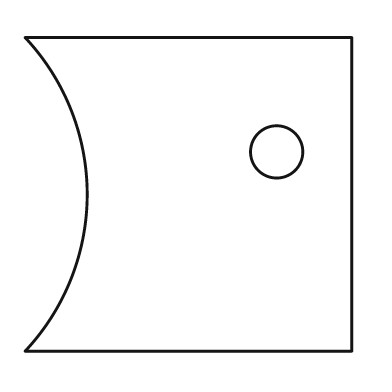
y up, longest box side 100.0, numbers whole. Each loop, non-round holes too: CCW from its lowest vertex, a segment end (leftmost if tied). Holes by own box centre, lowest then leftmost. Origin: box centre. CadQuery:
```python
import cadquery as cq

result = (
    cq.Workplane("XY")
    .moveTo(-50.0, -48.0)
    .lineTo(50.0, -48.0)
    .lineTo(50.0, 48.0)
    .lineTo(-50.0, 48.0)
    .threePointArc((-31.0, 0.0), (-50.0, -48.0))
    .close()
    .moveTo(27.0, 13.0)
    .circle(8.0)
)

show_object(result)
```